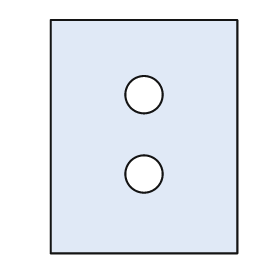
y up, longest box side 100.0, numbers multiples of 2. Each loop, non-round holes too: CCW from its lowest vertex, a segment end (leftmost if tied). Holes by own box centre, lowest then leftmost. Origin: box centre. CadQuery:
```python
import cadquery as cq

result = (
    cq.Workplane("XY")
    .moveTo(-40.0, -50.0)
    .lineTo(40.0, -50.0)
    .lineTo(40.0, 50.0)
    .lineTo(-40.0, 50.0)
    .close()
    .moveTo(0.0, -16.0)
    .circle(8.0)
    .moveTo(0.0, 18.0)
    .circle(8.0)
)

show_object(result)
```